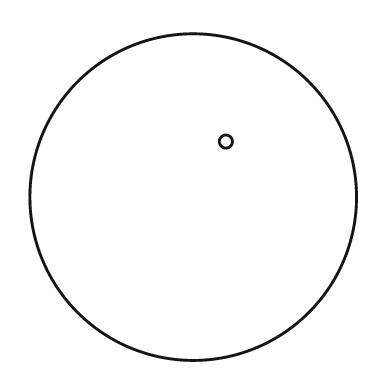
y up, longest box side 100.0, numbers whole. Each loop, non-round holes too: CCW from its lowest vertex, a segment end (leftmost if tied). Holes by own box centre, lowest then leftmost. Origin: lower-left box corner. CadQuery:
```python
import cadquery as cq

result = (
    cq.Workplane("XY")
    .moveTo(50.0, 50.0)
    .circle(50.0)
    .moveTo(60.0, 67.0)
    .circle(2.0)
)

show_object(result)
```